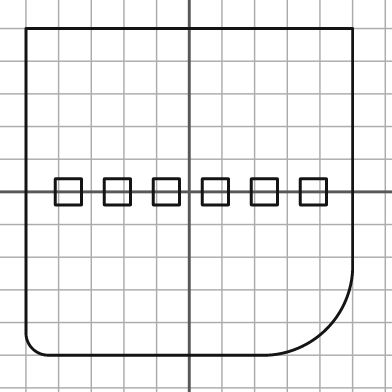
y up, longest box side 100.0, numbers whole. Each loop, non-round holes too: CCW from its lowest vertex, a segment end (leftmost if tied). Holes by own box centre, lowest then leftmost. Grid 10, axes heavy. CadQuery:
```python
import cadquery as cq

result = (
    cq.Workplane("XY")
    .moveTo(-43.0, -50.0)
    .lineTo(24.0, -50.0)
    .threePointArc((42.0, -42.0), (50.0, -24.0))
    .lineTo(50.0, 50.0)
    .lineTo(-50.0, 50.0)
    .lineTo(-50.0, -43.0)
    .threePointArc((-48.0, -48.0), (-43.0, -50.0))
    .close()
    .moveTo(-41.0, -4.0)
    .lineTo(-33.0, -4.0)
    .lineTo(-33.0, 4.0)
    .lineTo(-41.0, 4.0)
    .close()
    .moveTo(-26.0, -4.0)
    .lineTo(-18.0, -4.0)
    .lineTo(-18.0, 4.0)
    .lineTo(-26.0, 4.0)
    .close()
    .moveTo(-11.0, -4.0)
    .lineTo(-3.0, -4.0)
    .lineTo(-3.0, 4.0)
    .lineTo(-11.0, 4.0)
    .close()
    .moveTo(4.0, -4.0)
    .lineTo(12.0, -4.0)
    .lineTo(12.0, 4.0)
    .lineTo(4.0, 4.0)
    .close()
    .moveTo(19.0, -4.0)
    .lineTo(27.0, -4.0)
    .lineTo(27.0, 4.0)
    .lineTo(19.0, 4.0)
    .close()
    .moveTo(34.0, -4.0)
    .lineTo(42.0, -4.0)
    .lineTo(42.0, 4.0)
    .lineTo(34.0, 4.0)
    .close()
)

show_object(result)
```